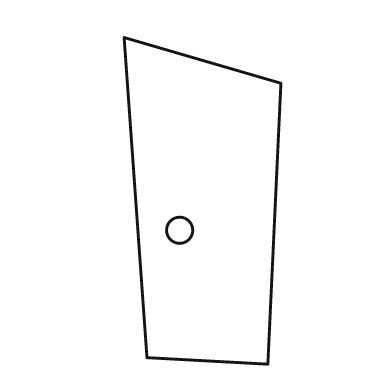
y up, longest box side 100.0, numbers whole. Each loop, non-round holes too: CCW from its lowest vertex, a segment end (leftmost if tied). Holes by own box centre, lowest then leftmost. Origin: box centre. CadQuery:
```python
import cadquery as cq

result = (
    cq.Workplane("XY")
    .moveTo(20.0, -50.0)
    .lineTo(24.0, 36.0)
    .lineTo(-24.0, 50.0)
    .lineTo(-17.0, -48.0)
    .close()
    .moveTo(-7.0, -9.0)
    .circle(4.0)
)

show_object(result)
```